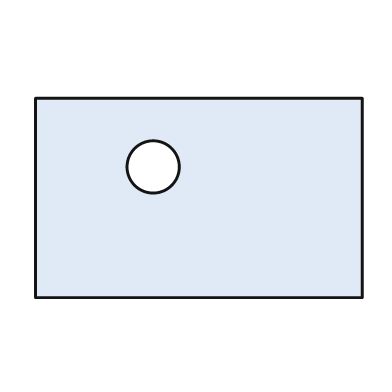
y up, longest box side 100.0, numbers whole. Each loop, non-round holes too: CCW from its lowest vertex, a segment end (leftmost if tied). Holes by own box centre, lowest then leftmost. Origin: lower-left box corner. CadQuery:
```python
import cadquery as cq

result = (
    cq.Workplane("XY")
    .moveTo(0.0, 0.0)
    .lineTo(100.0, 0.0)
    .lineTo(100.0, 61.0)
    .lineTo(0.0, 61.0)
    .close()
    .moveTo(36.0, 40.0)
    .circle(8.0)
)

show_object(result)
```